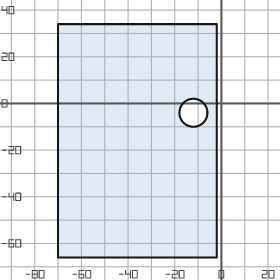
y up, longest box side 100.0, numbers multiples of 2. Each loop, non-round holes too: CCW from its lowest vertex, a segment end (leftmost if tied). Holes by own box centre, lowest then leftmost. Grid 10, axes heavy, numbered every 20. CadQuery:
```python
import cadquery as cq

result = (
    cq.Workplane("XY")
    .moveTo(-70.0, -66.0)
    .lineTo(-2.0, -66.0)
    .lineTo(-2.0, 34.0)
    .lineTo(-70.0, 34.0)
    .close()
    .moveTo(-12.0, -4.0)
    .circle(6.0)
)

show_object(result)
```